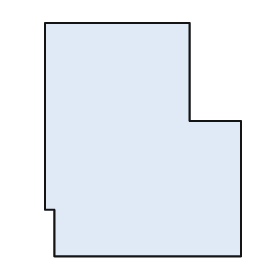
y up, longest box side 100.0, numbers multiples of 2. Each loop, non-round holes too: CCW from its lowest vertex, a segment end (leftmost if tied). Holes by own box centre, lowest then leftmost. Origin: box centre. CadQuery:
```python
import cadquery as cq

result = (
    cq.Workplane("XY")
    .moveTo(-38.0, -50.0)
    .lineTo(42.0, -50.0)
    .lineTo(42.0, 8.0)
    .lineTo(20.0, 8.0)
    .lineTo(20.0, 50.0)
    .lineTo(-42.0, 50.0)
    .lineTo(-42.0, -30.0)
    .lineTo(-38.0, -30.0)
    .close()
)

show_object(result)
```